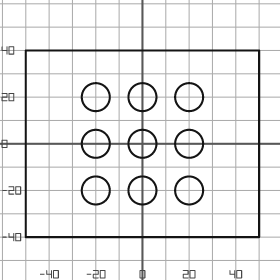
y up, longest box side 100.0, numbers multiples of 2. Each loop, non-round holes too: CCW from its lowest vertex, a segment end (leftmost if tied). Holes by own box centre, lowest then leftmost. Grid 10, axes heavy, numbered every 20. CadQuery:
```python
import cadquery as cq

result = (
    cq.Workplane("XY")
    .moveTo(-50.0, -40.0)
    .lineTo(50.0, -40.0)
    .lineTo(50.0, 40.0)
    .lineTo(-50.0, 40.0)
    .close()
    .moveTo(-20.0, -20.0)
    .circle(6.0)
    .moveTo(0.0, -20.0)
    .circle(6.0)
    .moveTo(20.0, -20.0)
    .circle(6.0)
    .moveTo(-20.0, 0.0)
    .circle(6.0)
    .moveTo(0.0, 0.0)
    .circle(6.0)
    .moveTo(20.0, 0.0)
    .circle(6.0)
    .moveTo(-20.0, 20.0)
    .circle(6.0)
    .moveTo(0.0, 20.0)
    .circle(6.0)
    .moveTo(20.0, 20.0)
    .circle(6.0)
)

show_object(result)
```